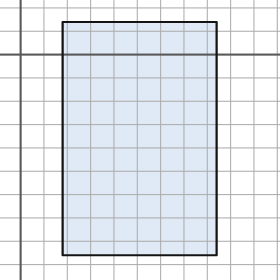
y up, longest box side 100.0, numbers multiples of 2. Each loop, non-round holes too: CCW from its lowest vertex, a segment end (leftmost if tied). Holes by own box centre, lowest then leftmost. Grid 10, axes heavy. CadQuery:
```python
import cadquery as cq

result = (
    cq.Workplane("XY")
    .moveTo(18.0, -86.0)
    .lineTo(84.0, -86.0)
    .lineTo(84.0, 14.0)
    .lineTo(18.0, 14.0)
    .close()
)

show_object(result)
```